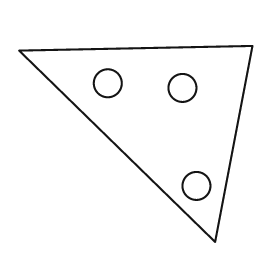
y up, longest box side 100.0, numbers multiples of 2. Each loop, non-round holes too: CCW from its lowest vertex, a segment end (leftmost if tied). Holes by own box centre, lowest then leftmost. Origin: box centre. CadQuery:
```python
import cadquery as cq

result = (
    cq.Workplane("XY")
    .moveTo(34.0, -42.0)
    .lineTo(50.0, 42.0)
    .lineTo(-50.0, 40.0)
    .close()
    .moveTo(26.0, -18.0)
    .circle(6.0)
    .moveTo(20.0, 24.0)
    .circle(6.0)
    .moveTo(-12.0, 26.0)
    .circle(6.0)
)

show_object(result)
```